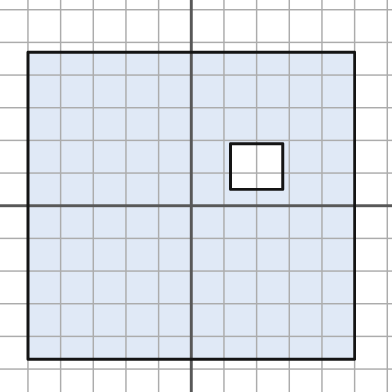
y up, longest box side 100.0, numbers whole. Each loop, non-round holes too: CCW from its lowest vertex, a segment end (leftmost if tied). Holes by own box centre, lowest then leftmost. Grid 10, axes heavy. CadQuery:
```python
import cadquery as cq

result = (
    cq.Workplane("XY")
    .moveTo(-50.0, -47.0)
    .lineTo(50.0, -47.0)
    .lineTo(50.0, 47.0)
    .lineTo(-50.0, 47.0)
    .close()
    .moveTo(12.0, 5.0)
    .lineTo(28.0, 5.0)
    .lineTo(28.0, 19.0)
    .lineTo(12.0, 19.0)
    .close()
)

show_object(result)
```